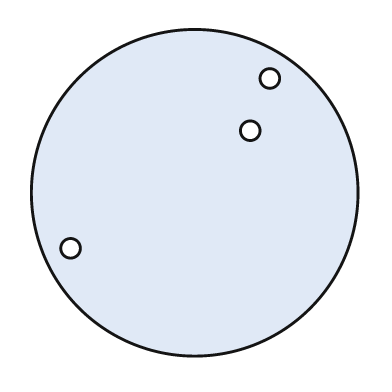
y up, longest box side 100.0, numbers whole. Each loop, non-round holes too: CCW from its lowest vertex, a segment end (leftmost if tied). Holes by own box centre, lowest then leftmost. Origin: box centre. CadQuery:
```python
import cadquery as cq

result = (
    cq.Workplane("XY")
    .moveTo(0.0, 0.0)
    .circle(50.0)
    .moveTo(-38.0, -17.0)
    .circle(3.0)
    .moveTo(17.0, 19.0)
    .circle(3.0)
    .moveTo(23.0, 35.0)
    .circle(3.0)
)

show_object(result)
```